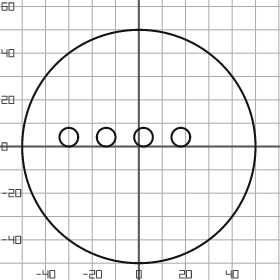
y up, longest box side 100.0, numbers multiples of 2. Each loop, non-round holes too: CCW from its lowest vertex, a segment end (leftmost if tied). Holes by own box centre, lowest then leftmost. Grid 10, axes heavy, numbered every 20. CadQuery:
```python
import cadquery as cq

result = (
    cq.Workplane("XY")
    .moveTo(0.0, 0.0)
    .circle(50.0)
    .moveTo(-30.0, 4.0)
    .circle(4.0)
    .moveTo(-14.0, 4.0)
    .circle(4.0)
    .moveTo(2.0, 4.0)
    .circle(4.0)
    .moveTo(18.0, 4.0)
    .circle(4.0)
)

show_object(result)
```